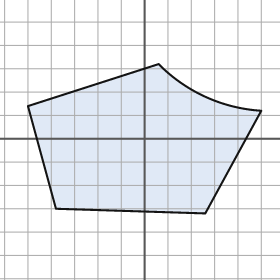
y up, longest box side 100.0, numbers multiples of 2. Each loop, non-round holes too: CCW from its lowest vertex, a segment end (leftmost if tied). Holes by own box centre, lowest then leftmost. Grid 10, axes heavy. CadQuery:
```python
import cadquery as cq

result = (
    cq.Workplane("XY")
    .moveTo(26.0, -32.0)
    .lineTo(50.0, 12.0)
    .threePointArc((26.0, 18.0), (6.0, 32.0))
    .lineTo(-50.0, 14.0)
    .lineTo(-38.0, -30.0)
    .close()
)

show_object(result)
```